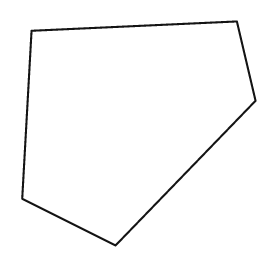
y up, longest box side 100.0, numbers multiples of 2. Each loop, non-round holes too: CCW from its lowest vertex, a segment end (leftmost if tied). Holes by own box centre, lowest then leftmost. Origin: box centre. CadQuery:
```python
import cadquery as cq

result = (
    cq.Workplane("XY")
    .moveTo(-10.0, -48.0)
    .lineTo(50.0, 14.0)
    .lineTo(42.0, 48.0)
    .lineTo(-46.0, 44.0)
    .lineTo(-50.0, -28.0)
    .close()
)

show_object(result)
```